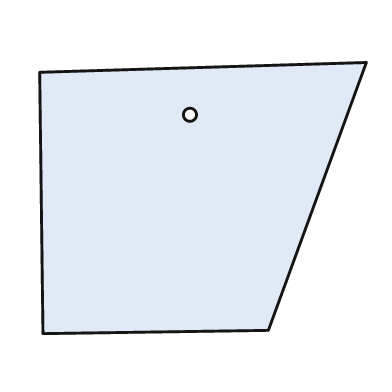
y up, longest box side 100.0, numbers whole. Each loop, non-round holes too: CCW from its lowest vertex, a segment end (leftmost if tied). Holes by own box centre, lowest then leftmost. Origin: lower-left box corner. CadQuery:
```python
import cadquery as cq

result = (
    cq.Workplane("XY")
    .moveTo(1.0, 0.0)
    .lineTo(70.0, 1.0)
    .lineTo(100.0, 83.0)
    .lineTo(0.0, 80.0)
    .close()
    .moveTo(46.0, 67.0)
    .circle(2.0)
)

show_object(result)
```